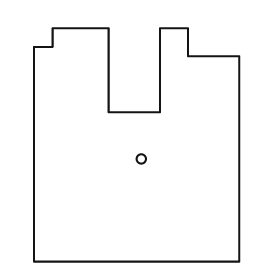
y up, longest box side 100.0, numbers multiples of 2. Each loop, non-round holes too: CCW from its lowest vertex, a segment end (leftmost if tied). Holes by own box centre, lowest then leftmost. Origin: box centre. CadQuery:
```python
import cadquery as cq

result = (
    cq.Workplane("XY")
    .moveTo(-44.0, -50.0)
    .lineTo(44.0, -50.0)
    .lineTo(44.0, 38.0)
    .lineTo(22.0, 38.0)
    .lineTo(22.0, 50.0)
    .lineTo(10.0, 50.0)
    .lineTo(10.0, 14.0)
    .lineTo(-12.0, 14.0)
    .lineTo(-12.0, 50.0)
    .lineTo(-36.0, 50.0)
    .lineTo(-36.0, 42.0)
    .lineTo(-44.0, 42.0)
    .close()
    .moveTo(2.0, -6.0)
    .circle(2.0)
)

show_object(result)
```